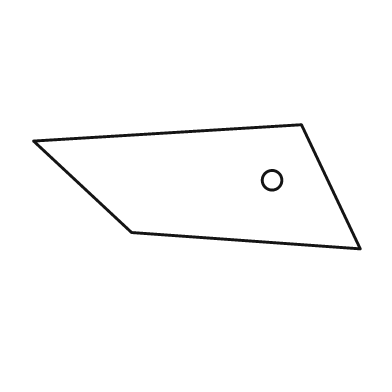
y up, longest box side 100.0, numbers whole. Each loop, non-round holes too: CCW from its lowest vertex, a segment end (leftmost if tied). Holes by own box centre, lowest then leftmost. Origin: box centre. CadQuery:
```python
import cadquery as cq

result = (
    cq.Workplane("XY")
    .moveTo(50.0, -19.0)
    .lineTo(32.0, 19.0)
    .lineTo(-50.0, 14.0)
    .lineTo(-20.0, -14.0)
    .close()
    .moveTo(23.0, 2.0)
    .circle(3.0)
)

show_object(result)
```